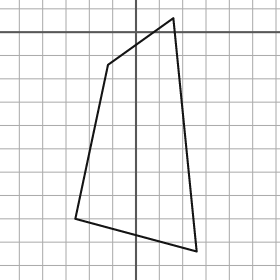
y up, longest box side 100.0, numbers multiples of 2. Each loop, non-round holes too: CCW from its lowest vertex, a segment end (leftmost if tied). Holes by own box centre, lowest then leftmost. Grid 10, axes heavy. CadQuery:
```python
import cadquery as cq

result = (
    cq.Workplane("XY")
    .moveTo(26.0, -94.0)
    .lineTo(16.0, 6.0)
    .lineTo(-12.0, -14.0)
    .lineTo(-26.0, -80.0)
    .close()
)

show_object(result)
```